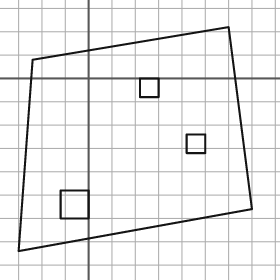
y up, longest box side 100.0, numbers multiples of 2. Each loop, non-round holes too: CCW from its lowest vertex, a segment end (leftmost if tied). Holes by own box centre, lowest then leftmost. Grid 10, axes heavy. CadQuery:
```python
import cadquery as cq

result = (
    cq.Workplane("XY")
    .moveTo(-30.0, -74.0)
    .lineTo(70.0, -56.0)
    .lineTo(60.0, 22.0)
    .lineTo(-24.0, 8.0)
    .close()
    .moveTo(-12.0, -60.0)
    .lineTo(0.0, -60.0)
    .lineTo(0.0, -48.0)
    .lineTo(-12.0, -48.0)
    .close()
    .moveTo(42.0, -32.0)
    .lineTo(50.0, -32.0)
    .lineTo(50.0, -24.0)
    .lineTo(42.0, -24.0)
    .close()
    .moveTo(22.0, -8.0)
    .lineTo(30.0, -8.0)
    .lineTo(30.0, 0.0)
    .lineTo(22.0, 0.0)
    .close()
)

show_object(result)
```